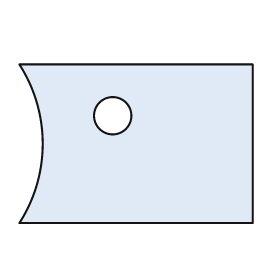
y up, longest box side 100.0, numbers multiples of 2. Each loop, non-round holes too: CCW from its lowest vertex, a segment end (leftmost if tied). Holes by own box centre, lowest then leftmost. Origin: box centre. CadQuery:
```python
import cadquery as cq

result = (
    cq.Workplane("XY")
    .moveTo(-50.0, -34.0)
    .lineTo(50.0, -34.0)
    .lineTo(50.0, 34.0)
    .lineTo(-50.0, 34.0)
    .threePointArc((-40.0, 0.0), (-50.0, -34.0))
    .close()
    .moveTo(-10.0, 12.0)
    .circle(8.0)
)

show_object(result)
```